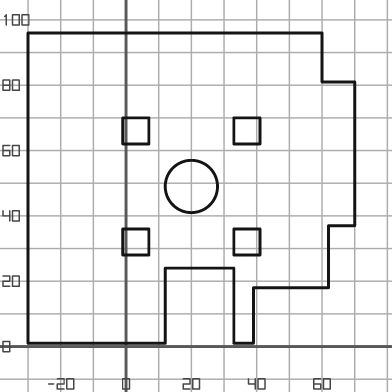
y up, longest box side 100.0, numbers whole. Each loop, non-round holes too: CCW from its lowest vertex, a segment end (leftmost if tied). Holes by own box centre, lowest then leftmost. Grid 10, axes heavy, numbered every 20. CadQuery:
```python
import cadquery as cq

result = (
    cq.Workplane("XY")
    .moveTo(-30.0, 1.0)
    .lineTo(12.0, 1.0)
    .lineTo(12.0, 24.0)
    .lineTo(33.0, 24.0)
    .lineTo(33.0, 1.0)
    .lineTo(39.0, 1.0)
    .lineTo(39.0, 18.0)
    .lineTo(62.0, 18.0)
    .lineTo(62.0, 37.0)
    .lineTo(70.0, 37.0)
    .lineTo(70.0, 81.0)
    .lineTo(60.0, 81.0)
    .lineTo(60.0, 96.0)
    .lineTo(-30.0, 96.0)
    .close()
    .moveTo(-1.0, 28.0)
    .lineTo(7.0, 28.0)
    .lineTo(7.0, 36.0)
    .lineTo(-1.0, 36.0)
    .close()
    .moveTo(33.0, 28.0)
    .lineTo(41.0, 28.0)
    .lineTo(41.0, 36.0)
    .lineTo(33.0, 36.0)
    .close()
    .moveTo(20.0, 49.0)
    .circle(8.0)
    .moveTo(-1.0, 62.0)
    .lineTo(7.0, 62.0)
    .lineTo(7.0, 70.0)
    .lineTo(-1.0, 70.0)
    .close()
    .moveTo(33.0, 62.0)
    .lineTo(41.0, 62.0)
    .lineTo(41.0, 70.0)
    .lineTo(33.0, 70.0)
    .close()
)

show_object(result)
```